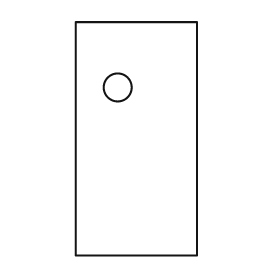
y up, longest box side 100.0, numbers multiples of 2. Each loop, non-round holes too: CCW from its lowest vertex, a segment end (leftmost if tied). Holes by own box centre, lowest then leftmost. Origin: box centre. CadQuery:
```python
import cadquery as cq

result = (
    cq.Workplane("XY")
    .moveTo(-26.0, -50.0)
    .lineTo(26.0, -50.0)
    .lineTo(26.0, 50.0)
    .lineTo(-26.0, 50.0)
    .close()
    .moveTo(-8.0, 22.0)
    .circle(6.0)
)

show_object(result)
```